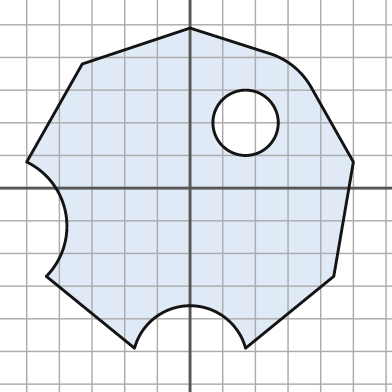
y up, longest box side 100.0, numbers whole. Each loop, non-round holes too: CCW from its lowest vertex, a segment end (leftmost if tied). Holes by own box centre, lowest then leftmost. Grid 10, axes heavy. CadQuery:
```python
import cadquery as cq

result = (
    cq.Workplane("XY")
    .moveTo(-17.0, -49.0)
    .threePointArc((0.0, -36.0), (17.0, -49.0))
    .lineTo(44.0, -27.0)
    .lineTo(50.0, 8.0)
    .lineTo(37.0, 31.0)
    .threePointArc((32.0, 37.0), (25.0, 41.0))
    .lineTo(0.0, 49.0)
    .lineTo(-33.0, 38.0)
    .lineTo(-50.0, 8.0)
    .threePointArc((-38.0, -8.0), (-44.0, -27.0))
    .close()
    .moveTo(17.0, 20.0)
    .circle(10.0)
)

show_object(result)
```